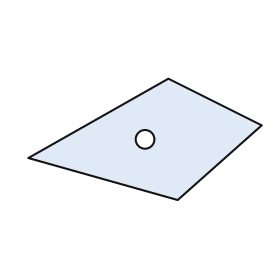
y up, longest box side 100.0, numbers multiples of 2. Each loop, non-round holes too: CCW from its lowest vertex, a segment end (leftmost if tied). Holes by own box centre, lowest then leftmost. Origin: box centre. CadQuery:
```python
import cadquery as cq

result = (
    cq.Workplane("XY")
    .moveTo(14.0, -26.0)
    .lineTo(50.0, 6.0)
    .lineTo(10.0, 26.0)
    .lineTo(-50.0, -8.0)
    .close()
    .moveTo(0.0, 0.0)
    .circle(4.0)
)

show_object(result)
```